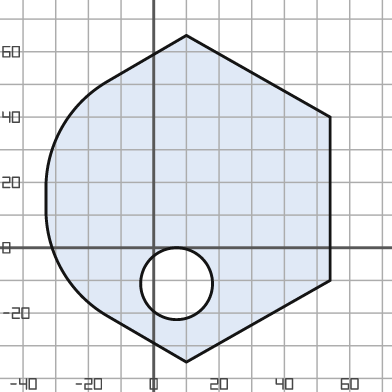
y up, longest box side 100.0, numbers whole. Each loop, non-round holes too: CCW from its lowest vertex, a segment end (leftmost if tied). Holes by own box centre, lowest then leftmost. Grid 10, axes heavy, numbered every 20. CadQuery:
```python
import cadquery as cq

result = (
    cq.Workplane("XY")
    .moveTo(10.0, -35.0)
    .lineTo(54.0, -10.0)
    .lineTo(54.0, 40.0)
    .lineTo(10.0, 65.0)
    .lineTo(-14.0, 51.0)
    .threePointArc((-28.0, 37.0), (-33.0, 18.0))
    .lineTo(-33.0, 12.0)
    .threePointArc((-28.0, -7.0), (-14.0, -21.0))
    .close()
    .moveTo(7.0, -11.0)
    .circle(11.0)
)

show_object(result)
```